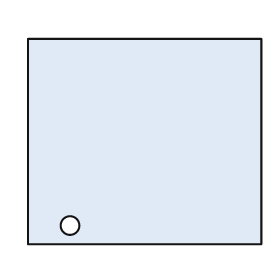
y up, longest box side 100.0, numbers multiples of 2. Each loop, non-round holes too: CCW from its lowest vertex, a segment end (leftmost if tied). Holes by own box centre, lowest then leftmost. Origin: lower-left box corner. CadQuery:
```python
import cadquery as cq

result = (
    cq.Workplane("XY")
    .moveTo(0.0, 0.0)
    .lineTo(100.0, 0.0)
    .lineTo(100.0, 88.0)
    .lineTo(0.0, 88.0)
    .close()
    .moveTo(18.0, 8.0)
    .circle(4.0)
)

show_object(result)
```